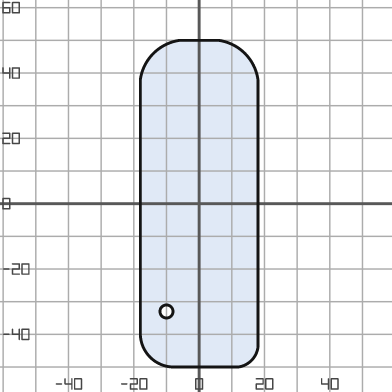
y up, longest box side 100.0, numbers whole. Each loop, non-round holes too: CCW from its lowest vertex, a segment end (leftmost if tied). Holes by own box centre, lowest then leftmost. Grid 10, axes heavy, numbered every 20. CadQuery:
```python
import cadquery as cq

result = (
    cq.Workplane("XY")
    .moveTo(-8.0, -50.0)
    .lineTo(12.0, -50.0)
    .threePointArc((16.0, -48.0), (18.0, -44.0))
    .lineTo(18.0, 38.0)
    .threePointArc((14.0, 46.0), (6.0, 50.0))
    .lineTo(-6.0, 50.0)
    .threePointArc((-14.0, 46.0), (-18.0, 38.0))
    .lineTo(-18.0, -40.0)
    .threePointArc((-15.0, -47.0), (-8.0, -50.0))
    .close()
    .moveTo(-10.0, -33.0)
    .circle(2.0)
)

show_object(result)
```